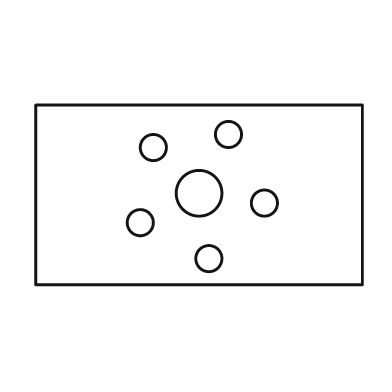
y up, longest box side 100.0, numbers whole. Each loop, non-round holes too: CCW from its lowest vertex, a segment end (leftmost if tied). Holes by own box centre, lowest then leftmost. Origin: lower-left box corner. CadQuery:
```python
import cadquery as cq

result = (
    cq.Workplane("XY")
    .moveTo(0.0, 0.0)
    .lineTo(100.0, 0.0)
    .lineTo(100.0, 55.0)
    .lineTo(0.0, 55.0)
    .close()
    .moveTo(53.0, 8.0)
    .circle(4.0)
    .moveTo(32.0, 19.0)
    .circle(4.0)
    .moveTo(70.0, 25.0)
    .circle(4.0)
    .moveTo(50.0, 28.0)
    .circle(7.0)
    .moveTo(36.0, 42.0)
    .circle(4.0)
    .moveTo(59.0, 46.0)
    .circle(4.0)
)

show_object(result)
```